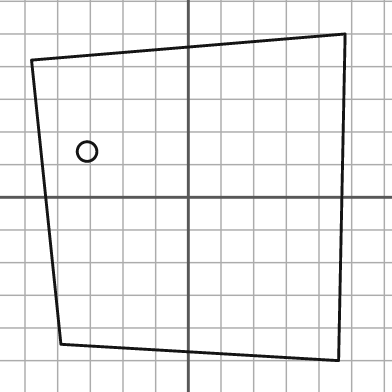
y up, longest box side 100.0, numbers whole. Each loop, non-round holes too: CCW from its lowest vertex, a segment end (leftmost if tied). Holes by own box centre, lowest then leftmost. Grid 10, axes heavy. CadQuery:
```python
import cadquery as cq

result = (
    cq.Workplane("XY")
    .moveTo(46.0, -50.0)
    .lineTo(48.0, 50.0)
    .lineTo(-48.0, 42.0)
    .lineTo(-39.0, -45.0)
    .close()
    .moveTo(-31.0, 14.0)
    .circle(3.0)
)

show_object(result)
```